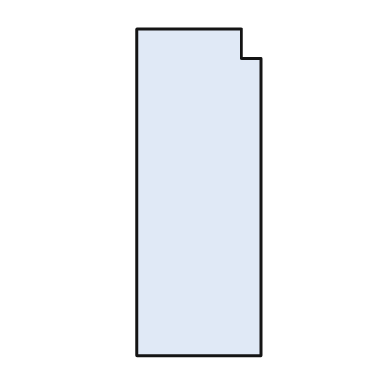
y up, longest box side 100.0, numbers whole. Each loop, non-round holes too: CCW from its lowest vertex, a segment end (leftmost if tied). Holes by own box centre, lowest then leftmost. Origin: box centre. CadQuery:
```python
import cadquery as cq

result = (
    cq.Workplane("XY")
    .moveTo(-19.0, -50.0)
    .lineTo(19.0, -50.0)
    .lineTo(19.0, 41.0)
    .lineTo(13.0, 41.0)
    .lineTo(13.0, 50.0)
    .lineTo(-19.0, 50.0)
    .close()
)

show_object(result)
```